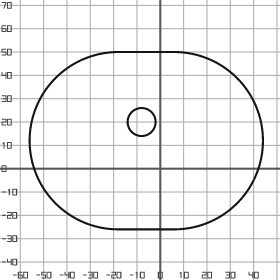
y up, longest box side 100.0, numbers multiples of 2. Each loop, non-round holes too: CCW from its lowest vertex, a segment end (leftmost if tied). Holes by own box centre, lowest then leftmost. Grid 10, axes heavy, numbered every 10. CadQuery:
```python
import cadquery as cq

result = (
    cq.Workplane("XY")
    .moveTo(-18.0, -26.0)
    .lineTo(6.0, -26.0)
    .threePointArc((44.0, 12.0), (6.0, 50.0))
    .lineTo(-18.0, 50.0)
    .threePointArc((-56.0, 12.0), (-18.0, -26.0))
    .close()
    .moveTo(-8.0, 20.0)
    .circle(6.0)
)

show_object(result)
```